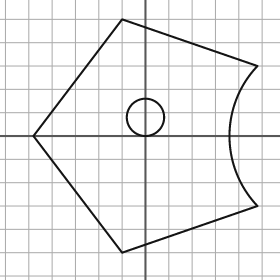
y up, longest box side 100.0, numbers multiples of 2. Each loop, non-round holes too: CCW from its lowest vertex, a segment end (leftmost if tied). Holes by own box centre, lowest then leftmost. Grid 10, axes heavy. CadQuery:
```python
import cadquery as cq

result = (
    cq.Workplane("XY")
    .moveTo(-10.0, -50.0)
    .lineTo(48.0, -30.0)
    .threePointArc((36.0, 0.0), (48.0, 30.0))
    .lineTo(-10.0, 50.0)
    .lineTo(-48.0, 0.0)
    .close()
    .moveTo(0.0, 8.0)
    .circle(8.0)
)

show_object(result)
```